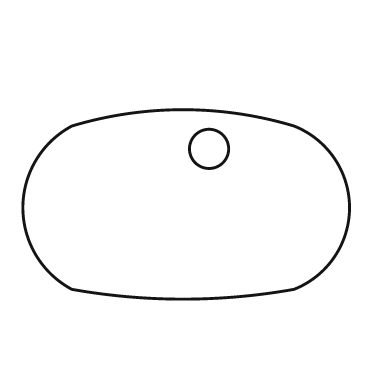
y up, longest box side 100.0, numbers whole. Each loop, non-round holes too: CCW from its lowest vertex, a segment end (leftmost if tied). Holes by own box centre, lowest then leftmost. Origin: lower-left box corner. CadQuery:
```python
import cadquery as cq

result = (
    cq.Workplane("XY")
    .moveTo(15.0, 3.0)
    .threePointArc((49.0, 0.0), (83.0, 3.0))
    .threePointArc((100.0, 28.0), (83.0, 53.0))
    .threePointArc((49.0, 58.0), (15.0, 53.0))
    .threePointArc((0.0, 28.0), (15.0, 3.0))
    .close()
    .moveTo(57.0, 46.0)
    .circle(6.0)
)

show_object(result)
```